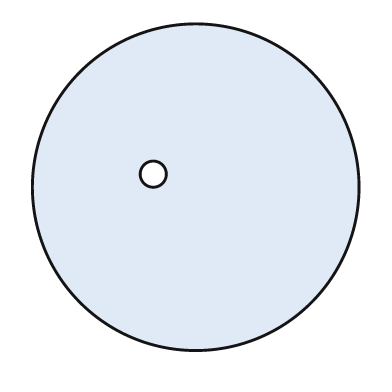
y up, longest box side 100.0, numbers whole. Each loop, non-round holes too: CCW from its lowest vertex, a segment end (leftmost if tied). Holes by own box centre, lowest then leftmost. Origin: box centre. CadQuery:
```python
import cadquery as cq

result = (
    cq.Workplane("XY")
    .moveTo(0.0, 0.0)
    .circle(50.0)
    .moveTo(-13.0, 4.0)
    .circle(4.0)
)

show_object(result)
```